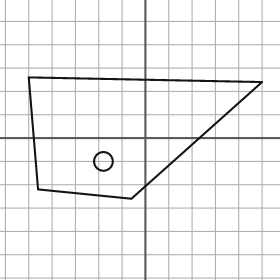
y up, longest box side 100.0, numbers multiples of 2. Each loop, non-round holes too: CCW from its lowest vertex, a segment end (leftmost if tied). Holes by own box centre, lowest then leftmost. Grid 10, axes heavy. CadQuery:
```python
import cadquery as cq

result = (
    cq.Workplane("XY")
    .moveTo(-6.0, -26.0)
    .lineTo(50.0, 24.0)
    .lineTo(-50.0, 26.0)
    .lineTo(-46.0, -22.0)
    .close()
    .moveTo(-18.0, -10.0)
    .circle(4.0)
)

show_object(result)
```